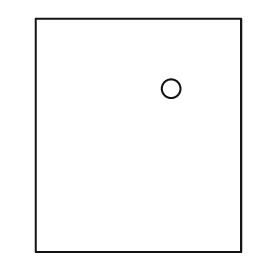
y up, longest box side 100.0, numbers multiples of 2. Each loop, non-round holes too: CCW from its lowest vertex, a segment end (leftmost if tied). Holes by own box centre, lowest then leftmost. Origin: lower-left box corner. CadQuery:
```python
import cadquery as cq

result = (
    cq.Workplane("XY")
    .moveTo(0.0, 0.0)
    .lineTo(88.0, 0.0)
    .lineTo(88.0, 100.0)
    .lineTo(0.0, 100.0)
    .close()
    .moveTo(58.0, 70.0)
    .circle(4.0)
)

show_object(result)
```